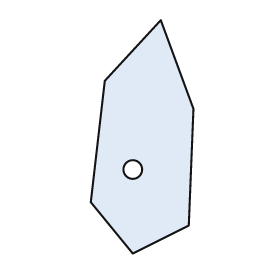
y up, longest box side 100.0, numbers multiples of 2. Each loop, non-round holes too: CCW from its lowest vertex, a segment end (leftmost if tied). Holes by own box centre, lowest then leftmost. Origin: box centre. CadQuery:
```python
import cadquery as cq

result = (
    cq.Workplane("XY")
    .moveTo(-4.0, -50.0)
    .lineTo(20.0, -38.0)
    .lineTo(22.0, 12.0)
    .lineTo(8.0, 50.0)
    .lineTo(-16.0, 24.0)
    .lineTo(-22.0, -28.0)
    .close()
    .moveTo(-4.0, -14.0)
    .circle(4.0)
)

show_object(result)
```